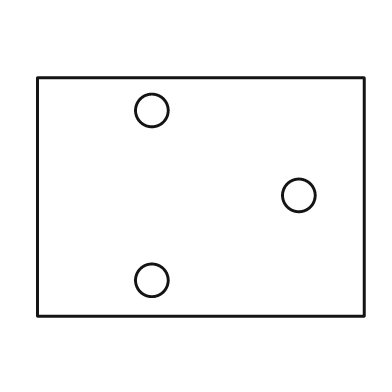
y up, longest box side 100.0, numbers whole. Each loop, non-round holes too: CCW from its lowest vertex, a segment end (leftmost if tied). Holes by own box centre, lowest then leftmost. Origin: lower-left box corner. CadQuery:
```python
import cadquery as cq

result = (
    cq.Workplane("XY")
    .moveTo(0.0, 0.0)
    .lineTo(100.0, 0.0)
    .lineTo(100.0, 73.0)
    .lineTo(0.0, 73.0)
    .close()
    .moveTo(35.0, 11.0)
    .circle(5.0)
    .moveTo(80.0, 37.0)
    .circle(5.0)
    .moveTo(35.0, 63.0)
    .circle(5.0)
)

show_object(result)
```